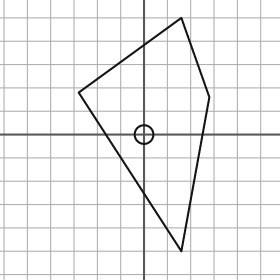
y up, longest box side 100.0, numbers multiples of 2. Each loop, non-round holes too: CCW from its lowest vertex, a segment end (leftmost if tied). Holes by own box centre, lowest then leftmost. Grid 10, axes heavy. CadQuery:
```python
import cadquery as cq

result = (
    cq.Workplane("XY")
    .moveTo(16.0, -50.0)
    .lineTo(28.0, 16.0)
    .lineTo(16.0, 50.0)
    .lineTo(-28.0, 18.0)
    .close()
    .moveTo(0.0, 0.0)
    .circle(4.0)
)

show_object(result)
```